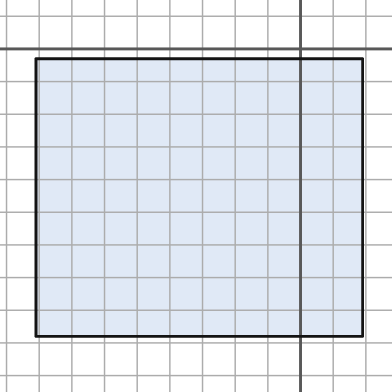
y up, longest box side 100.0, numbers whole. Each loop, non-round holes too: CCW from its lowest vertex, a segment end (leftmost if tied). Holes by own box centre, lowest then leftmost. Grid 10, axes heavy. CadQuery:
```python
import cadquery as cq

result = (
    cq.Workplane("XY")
    .moveTo(-81.0, -88.0)
    .lineTo(19.0, -88.0)
    .lineTo(19.0, -3.0)
    .lineTo(-81.0, -3.0)
    .close()
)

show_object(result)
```